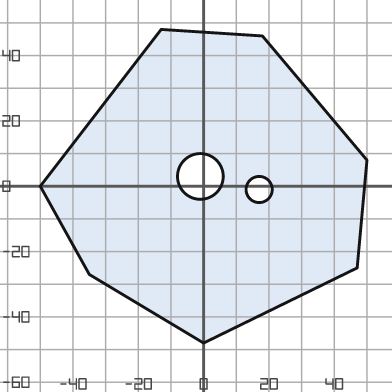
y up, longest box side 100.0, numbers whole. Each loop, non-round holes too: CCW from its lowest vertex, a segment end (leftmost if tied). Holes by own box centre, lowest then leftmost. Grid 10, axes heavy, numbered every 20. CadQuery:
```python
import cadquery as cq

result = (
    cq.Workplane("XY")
    .moveTo(0.0, -48.0)
    .lineTo(47.0, -25.0)
    .lineTo(50.0, 8.0)
    .lineTo(18.0, 46.0)
    .lineTo(-13.0, 48.0)
    .lineTo(-50.0, 0.0)
    .lineTo(-35.0, -27.0)
    .close()
    .moveTo(17.0, -1.0)
    .circle(4.0)
    .moveTo(-1.0, 3.0)
    .circle(7.0)
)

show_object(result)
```